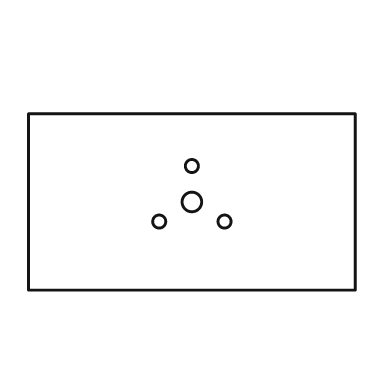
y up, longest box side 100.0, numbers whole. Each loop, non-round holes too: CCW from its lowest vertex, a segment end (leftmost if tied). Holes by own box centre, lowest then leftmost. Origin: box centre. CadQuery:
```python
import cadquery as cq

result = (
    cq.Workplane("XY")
    .moveTo(-50.0, -27.0)
    .lineTo(50.0, -27.0)
    .lineTo(50.0, 27.0)
    .lineTo(-50.0, 27.0)
    .close()
    .moveTo(-10.0, -6.0)
    .circle(2.0)
    .moveTo(10.0, -6.0)
    .circle(2.0)
    .moveTo(0.0, 0.0)
    .circle(3.0)
    .moveTo(0.0, 11.0)
    .circle(2.0)
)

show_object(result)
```